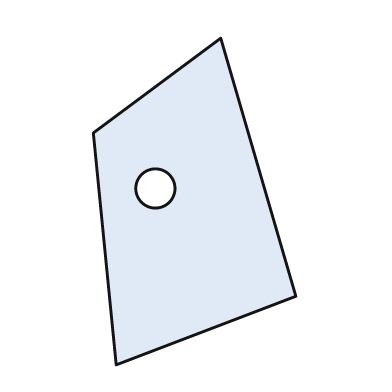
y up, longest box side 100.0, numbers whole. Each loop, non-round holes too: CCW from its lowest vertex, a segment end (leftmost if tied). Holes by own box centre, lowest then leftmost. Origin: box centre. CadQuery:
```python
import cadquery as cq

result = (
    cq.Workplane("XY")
    .moveTo(-24.0, -50.0)
    .lineTo(31.0, -29.0)
    .lineTo(8.0, 50.0)
    .lineTo(-31.0, 21.0)
    .close()
    .moveTo(-12.0, 4.0)
    .circle(6.0)
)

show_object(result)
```